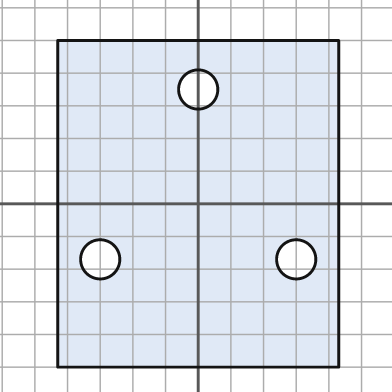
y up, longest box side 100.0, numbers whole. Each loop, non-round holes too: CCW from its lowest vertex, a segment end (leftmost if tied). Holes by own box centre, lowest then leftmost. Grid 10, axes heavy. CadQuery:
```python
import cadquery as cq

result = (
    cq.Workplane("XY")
    .moveTo(-43.0, -50.0)
    .lineTo(43.0, -50.0)
    .lineTo(43.0, 50.0)
    .lineTo(-43.0, 50.0)
    .close()
    .moveTo(-30.0, -17.0)
    .circle(6.0)
    .moveTo(30.0, -17.0)
    .circle(6.0)
    .moveTo(0.0, 35.0)
    .circle(6.0)
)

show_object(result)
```